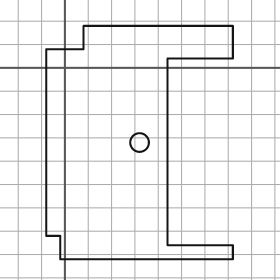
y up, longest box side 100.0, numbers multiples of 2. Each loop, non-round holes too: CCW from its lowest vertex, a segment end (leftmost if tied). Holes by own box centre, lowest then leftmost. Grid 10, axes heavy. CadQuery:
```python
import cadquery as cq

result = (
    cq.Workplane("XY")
    .moveTo(-2.0, -82.0)
    .lineTo(72.0, -82.0)
    .lineTo(72.0, -76.0)
    .lineTo(44.0, -76.0)
    .lineTo(44.0, 4.0)
    .lineTo(72.0, 4.0)
    .lineTo(72.0, 18.0)
    .lineTo(8.0, 18.0)
    .lineTo(8.0, 8.0)
    .lineTo(-8.0, 8.0)
    .lineTo(-8.0, -72.0)
    .lineTo(-2.0, -72.0)
    .close()
    .moveTo(32.0, -32.0)
    .circle(4.0)
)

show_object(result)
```